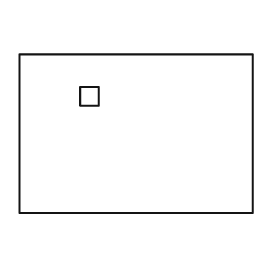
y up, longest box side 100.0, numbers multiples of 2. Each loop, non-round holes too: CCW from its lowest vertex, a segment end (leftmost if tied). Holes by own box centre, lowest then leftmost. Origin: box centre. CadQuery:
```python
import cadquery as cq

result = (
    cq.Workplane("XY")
    .moveTo(-50.0, -34.0)
    .lineTo(50.0, -34.0)
    .lineTo(50.0, 34.0)
    .lineTo(-50.0, 34.0)
    .close()
    .moveTo(-24.0, 12.0)
    .lineTo(-16.0, 12.0)
    .lineTo(-16.0, 20.0)
    .lineTo(-24.0, 20.0)
    .close()
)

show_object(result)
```